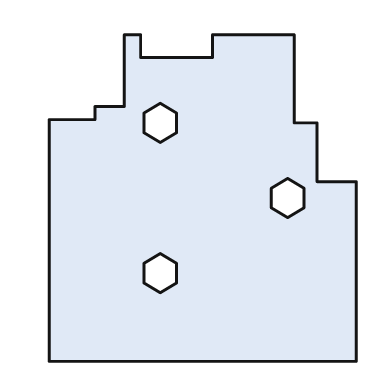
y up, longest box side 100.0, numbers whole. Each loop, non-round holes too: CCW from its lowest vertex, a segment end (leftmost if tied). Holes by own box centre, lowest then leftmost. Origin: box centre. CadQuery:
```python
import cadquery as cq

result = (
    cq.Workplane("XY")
    .moveTo(-47.0, -50.0)
    .lineTo(47.0, -50.0)
    .lineTo(47.0, 5.0)
    .lineTo(35.0, 5.0)
    .lineTo(35.0, 23.0)
    .lineTo(28.0, 23.0)
    .lineTo(28.0, 50.0)
    .lineTo(3.0, 50.0)
    .lineTo(3.0, 43.0)
    .lineTo(-19.0, 43.0)
    .lineTo(-19.0, 50.0)
    .lineTo(-24.0, 50.0)
    .lineTo(-24.0, 28.0)
    .lineTo(-33.0, 28.0)
    .lineTo(-33.0, 24.0)
    .lineTo(-47.0, 24.0)
    .close()
    .moveTo(-13.0, -29.0)
    .lineTo(-8.0, -26.0)
    .lineTo(-8.0, -20.0)
    .lineTo(-13.0, -17.0)
    .lineTo(-18.0, -20.0)
    .lineTo(-18.0, -26.0)
    .close()
    .moveTo(26.0, -6.0)
    .lineTo(31.0, -3.0)
    .lineTo(31.0, 3.0)
    .lineTo(26.0, 6.0)
    .lineTo(21.0, 3.0)
    .lineTo(21.0, -3.0)
    .close()
    .moveTo(-13.0, 17.0)
    .lineTo(-8.0, 20.0)
    .lineTo(-8.0, 26.0)
    .lineTo(-13.0, 29.0)
    .lineTo(-18.0, 26.0)
    .lineTo(-18.0, 20.0)
    .close()
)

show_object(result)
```